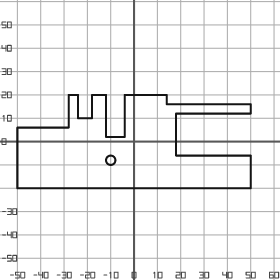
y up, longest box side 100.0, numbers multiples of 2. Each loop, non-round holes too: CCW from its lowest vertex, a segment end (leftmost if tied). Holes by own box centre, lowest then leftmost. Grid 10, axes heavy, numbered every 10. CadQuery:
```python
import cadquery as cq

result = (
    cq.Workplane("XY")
    .moveTo(-50.0, -20.0)
    .lineTo(50.0, -20.0)
    .lineTo(50.0, -6.0)
    .lineTo(18.0, -6.0)
    .lineTo(18.0, 12.0)
    .lineTo(50.0, 12.0)
    .lineTo(50.0, 16.0)
    .lineTo(14.0, 16.0)
    .lineTo(14.0, 20.0)
    .lineTo(-4.0, 20.0)
    .lineTo(-4.0, 2.0)
    .lineTo(-12.0, 2.0)
    .lineTo(-12.0, 20.0)
    .lineTo(-18.0, 20.0)
    .lineTo(-18.0, 10.0)
    .lineTo(-24.0, 10.0)
    .lineTo(-24.0, 20.0)
    .lineTo(-28.0, 20.0)
    .lineTo(-28.0, 6.0)
    .lineTo(-50.0, 6.0)
    .close()
    .moveTo(-10.0, -8.0)
    .circle(2.0)
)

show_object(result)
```